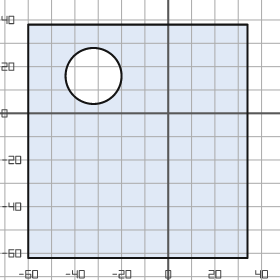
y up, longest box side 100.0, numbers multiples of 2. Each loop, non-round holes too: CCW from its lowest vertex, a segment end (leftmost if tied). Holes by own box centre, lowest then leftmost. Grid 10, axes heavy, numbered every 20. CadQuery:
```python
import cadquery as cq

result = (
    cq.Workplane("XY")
    .moveTo(-60.0, -62.0)
    .lineTo(34.0, -62.0)
    .lineTo(34.0, 38.0)
    .lineTo(-60.0, 38.0)
    .close()
    .moveTo(-32.0, 16.0)
    .circle(12.0)
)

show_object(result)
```